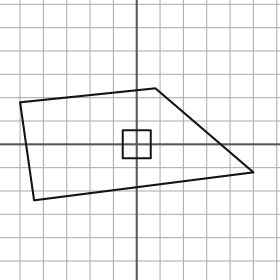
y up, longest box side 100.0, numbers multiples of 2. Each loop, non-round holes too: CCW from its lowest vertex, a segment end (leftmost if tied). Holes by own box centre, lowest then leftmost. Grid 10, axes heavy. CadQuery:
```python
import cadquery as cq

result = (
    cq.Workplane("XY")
    .moveTo(-44.0, -24.0)
    .lineTo(50.0, -12.0)
    .lineTo(8.0, 24.0)
    .lineTo(-50.0, 18.0)
    .close()
    .moveTo(-6.0, -6.0)
    .lineTo(6.0, -6.0)
    .lineTo(6.0, 6.0)
    .lineTo(-6.0, 6.0)
    .close()
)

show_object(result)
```